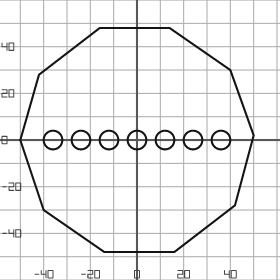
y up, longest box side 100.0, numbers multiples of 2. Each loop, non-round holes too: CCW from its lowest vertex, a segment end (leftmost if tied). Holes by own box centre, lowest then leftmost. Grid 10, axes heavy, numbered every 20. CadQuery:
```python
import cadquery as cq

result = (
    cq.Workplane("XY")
    .moveTo(-14.0, -48.0)
    .lineTo(16.0, -48.0)
    .lineTo(42.0, -28.0)
    .lineTo(50.0, 2.0)
    .lineTo(40.0, 30.0)
    .lineTo(14.0, 48.0)
    .lineTo(-16.0, 48.0)
    .lineTo(-42.0, 28.0)
    .lineTo(-50.0, 0.0)
    .lineTo(-40.0, -30.0)
    .close()
    .moveTo(-36.0, 0.0)
    .circle(4.0)
    .moveTo(-24.0, 0.0)
    .circle(4.0)
    .moveTo(-12.0, 0.0)
    .circle(4.0)
    .moveTo(0.0, 0.0)
    .circle(4.0)
    .moveTo(12.0, 0.0)
    .circle(4.0)
    .moveTo(24.0, 0.0)
    .circle(4.0)
    .moveTo(36.0, 0.0)
    .circle(4.0)
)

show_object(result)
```